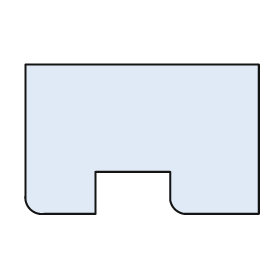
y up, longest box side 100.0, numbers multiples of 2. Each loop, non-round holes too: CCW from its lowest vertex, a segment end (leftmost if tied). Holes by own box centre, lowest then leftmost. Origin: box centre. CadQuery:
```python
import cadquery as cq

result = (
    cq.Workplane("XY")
    .moveTo(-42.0, -32.0)
    .lineTo(-20.0, -32.0)
    .lineTo(-20.0, -14.0)
    .lineTo(12.0, -14.0)
    .lineTo(12.0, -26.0)
    .threePointArc((14.0, -30.0), (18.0, -32.0))
    .lineTo(50.0, -32.0)
    .lineTo(50.0, 32.0)
    .lineTo(-50.0, 32.0)
    .lineTo(-50.0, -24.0)
    .threePointArc((-48.0, -30.0), (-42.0, -32.0))
    .close()
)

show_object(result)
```